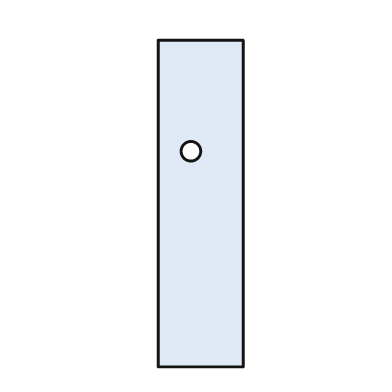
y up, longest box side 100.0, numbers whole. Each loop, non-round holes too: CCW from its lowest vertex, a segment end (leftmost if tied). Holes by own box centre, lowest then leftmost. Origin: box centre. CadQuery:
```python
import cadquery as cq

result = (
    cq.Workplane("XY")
    .moveTo(-13.0, -50.0)
    .lineTo(13.0, -50.0)
    .lineTo(13.0, 50.0)
    .lineTo(-13.0, 50.0)
    .close()
    .moveTo(-3.0, 16.0)
    .circle(3.0)
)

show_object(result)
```